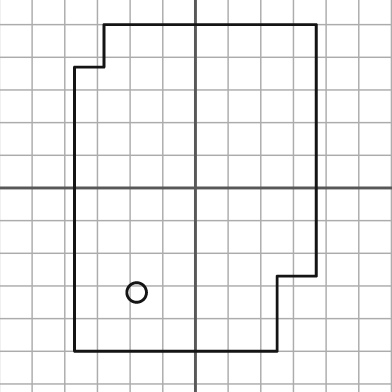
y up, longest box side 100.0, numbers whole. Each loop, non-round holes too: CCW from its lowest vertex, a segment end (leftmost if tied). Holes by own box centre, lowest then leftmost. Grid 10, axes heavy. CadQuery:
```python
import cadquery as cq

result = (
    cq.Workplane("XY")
    .moveTo(-37.0, -50.0)
    .lineTo(25.0, -50.0)
    .lineTo(25.0, -27.0)
    .lineTo(37.0, -27.0)
    .lineTo(37.0, 50.0)
    .lineTo(-28.0, 50.0)
    .lineTo(-28.0, 37.0)
    .lineTo(-37.0, 37.0)
    .close()
    .moveTo(-18.0, -32.0)
    .circle(3.0)
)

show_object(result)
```